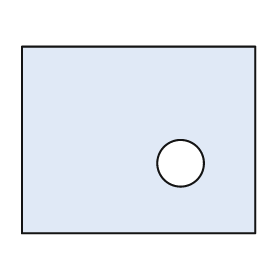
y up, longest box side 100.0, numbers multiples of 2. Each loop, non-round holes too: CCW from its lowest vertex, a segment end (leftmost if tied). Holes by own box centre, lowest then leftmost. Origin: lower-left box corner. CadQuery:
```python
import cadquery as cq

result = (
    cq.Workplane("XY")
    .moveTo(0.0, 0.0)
    .lineTo(100.0, 0.0)
    .lineTo(100.0, 80.0)
    .lineTo(0.0, 80.0)
    .close()
    .moveTo(68.0, 30.0)
    .circle(10.0)
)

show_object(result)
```